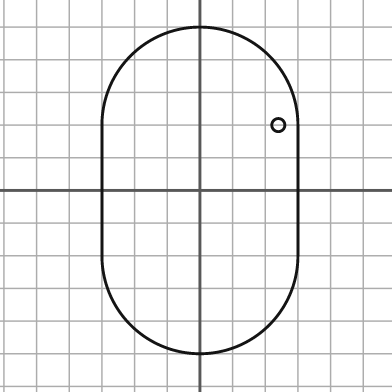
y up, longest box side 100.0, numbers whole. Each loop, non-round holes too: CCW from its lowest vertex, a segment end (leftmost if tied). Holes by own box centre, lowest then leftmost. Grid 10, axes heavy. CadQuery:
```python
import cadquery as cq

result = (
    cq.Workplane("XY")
    .moveTo(-30.0, -20.0)
    .threePointArc((0.0, -50.0), (30.0, -20.0))
    .lineTo(30.0, 20.0)
    .threePointArc((0.0, 50.0), (-30.0, 20.0))
    .close()
    .moveTo(24.0, 20.0)
    .circle(2.0)
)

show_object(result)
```